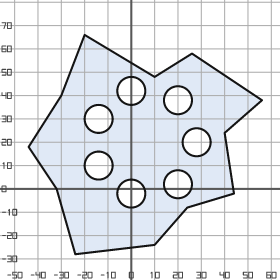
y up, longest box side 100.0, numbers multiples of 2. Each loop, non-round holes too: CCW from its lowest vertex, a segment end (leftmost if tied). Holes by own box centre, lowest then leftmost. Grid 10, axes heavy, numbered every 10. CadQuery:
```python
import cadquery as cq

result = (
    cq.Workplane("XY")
    .moveTo(-24.0, -28.0)
    .lineTo(10.0, -24.0)
    .lineTo(24.0, -8.0)
    .lineTo(44.0, -2.0)
    .lineTo(40.0, 24.0)
    .lineTo(56.0, 38.0)
    .lineTo(26.0, 58.0)
    .lineTo(10.0, 48.0)
    .lineTo(-20.0, 66.0)
    .lineTo(-30.0, 40.0)
    .lineTo(-44.0, 18.0)
    .lineTo(-32.0, 0.0)
    .close()
    .moveTo(0.0, -2.0)
    .circle(6.0)
    .moveTo(20.0, 2.0)
    .circle(6.0)
    .moveTo(-14.0, 10.0)
    .circle(6.0)
    .moveTo(28.0, 20.0)
    .circle(6.0)
    .moveTo(-14.0, 30.0)
    .circle(6.0)
    .moveTo(20.0, 38.0)
    .circle(6.0)
    .moveTo(0.0, 42.0)
    .circle(6.0)
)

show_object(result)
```